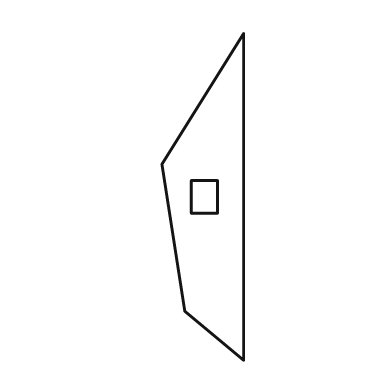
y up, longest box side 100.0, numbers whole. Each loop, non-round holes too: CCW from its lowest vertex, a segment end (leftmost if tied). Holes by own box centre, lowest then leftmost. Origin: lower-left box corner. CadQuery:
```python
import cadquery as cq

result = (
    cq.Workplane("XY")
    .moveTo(25.0, 0.0)
    .lineTo(25.0, 100.0)
    .lineTo(0.0, 60.0)
    .lineTo(7.0, 15.0)
    .close()
    .moveTo(9.0, 45.0)
    .lineTo(17.0, 45.0)
    .lineTo(17.0, 55.0)
    .lineTo(9.0, 55.0)
    .close()
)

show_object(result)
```